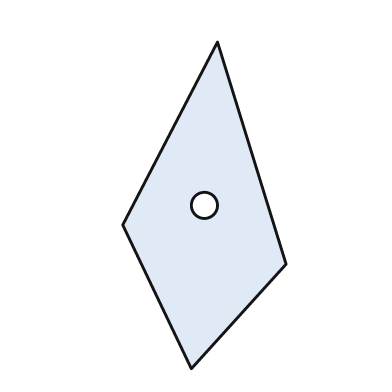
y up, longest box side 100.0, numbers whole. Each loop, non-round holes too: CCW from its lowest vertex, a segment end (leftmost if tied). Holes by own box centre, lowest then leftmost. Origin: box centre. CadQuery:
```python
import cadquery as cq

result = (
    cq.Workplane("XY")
    .moveTo(-4.0, -50.0)
    .lineTo(25.0, -18.0)
    .lineTo(4.0, 50.0)
    .lineTo(-25.0, -6.0)
    .close()
    .moveTo(0.0, 0.0)
    .circle(4.0)
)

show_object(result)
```